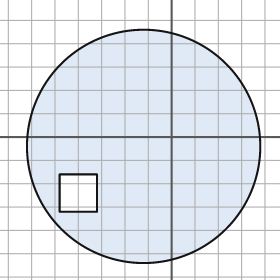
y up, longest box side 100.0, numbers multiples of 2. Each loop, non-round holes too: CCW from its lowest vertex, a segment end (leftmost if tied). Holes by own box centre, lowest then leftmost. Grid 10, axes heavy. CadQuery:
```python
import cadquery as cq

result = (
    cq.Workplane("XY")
    .moveTo(-12.0, -4.0)
    .circle(50.0)
    .moveTo(-48.0, -32.0)
    .lineTo(-32.0, -32.0)
    .lineTo(-32.0, -16.0)
    .lineTo(-48.0, -16.0)
    .close()
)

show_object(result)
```